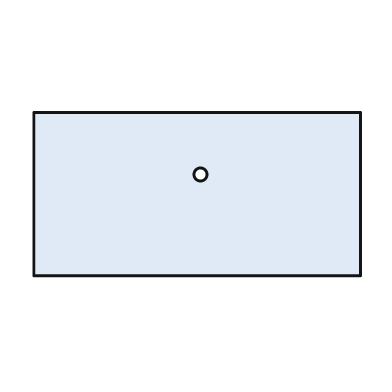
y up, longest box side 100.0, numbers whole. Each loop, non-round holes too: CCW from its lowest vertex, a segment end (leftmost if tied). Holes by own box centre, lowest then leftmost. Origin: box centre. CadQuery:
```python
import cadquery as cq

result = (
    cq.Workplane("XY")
    .moveTo(-50.0, -25.0)
    .lineTo(50.0, -25.0)
    .lineTo(50.0, 25.0)
    .lineTo(-50.0, 25.0)
    .close()
    .moveTo(1.0, 6.0)
    .circle(2.0)
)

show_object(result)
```